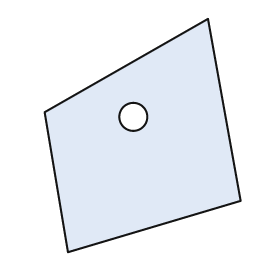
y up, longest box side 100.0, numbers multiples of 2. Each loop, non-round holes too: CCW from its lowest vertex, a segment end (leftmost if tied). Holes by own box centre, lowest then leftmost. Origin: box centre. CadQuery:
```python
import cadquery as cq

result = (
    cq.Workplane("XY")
    .moveTo(-32.0, -50.0)
    .lineTo(42.0, -28.0)
    .lineTo(28.0, 50.0)
    .lineTo(-42.0, 10.0)
    .close()
    .moveTo(-4.0, 8.0)
    .circle(6.0)
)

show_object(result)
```